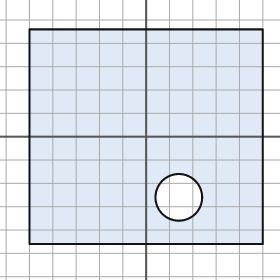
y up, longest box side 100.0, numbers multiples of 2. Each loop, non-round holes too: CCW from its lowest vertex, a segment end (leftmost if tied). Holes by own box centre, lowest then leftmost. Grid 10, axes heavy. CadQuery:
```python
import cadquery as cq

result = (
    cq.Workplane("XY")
    .moveTo(-50.0, -46.0)
    .lineTo(50.0, -46.0)
    .lineTo(50.0, 46.0)
    .lineTo(-50.0, 46.0)
    .close()
    .moveTo(14.0, -26.0)
    .circle(10.0)
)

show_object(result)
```